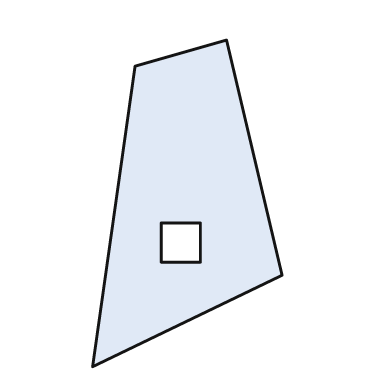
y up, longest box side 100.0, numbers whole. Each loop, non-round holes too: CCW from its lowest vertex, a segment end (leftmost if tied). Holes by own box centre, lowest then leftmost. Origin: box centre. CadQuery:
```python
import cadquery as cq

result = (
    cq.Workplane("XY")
    .moveTo(-29.0, -50.0)
    .lineTo(29.0, -22.0)
    .lineTo(12.0, 50.0)
    .lineTo(-16.0, 42.0)
    .close()
    .moveTo(-8.0, -18.0)
    .lineTo(4.0, -18.0)
    .lineTo(4.0, -6.0)
    .lineTo(-8.0, -6.0)
    .close()
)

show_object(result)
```